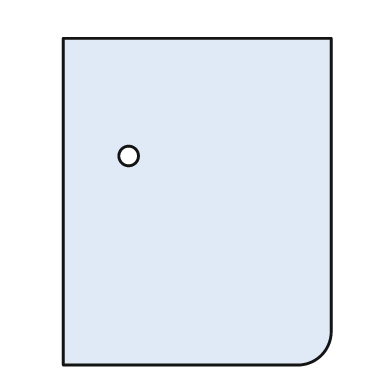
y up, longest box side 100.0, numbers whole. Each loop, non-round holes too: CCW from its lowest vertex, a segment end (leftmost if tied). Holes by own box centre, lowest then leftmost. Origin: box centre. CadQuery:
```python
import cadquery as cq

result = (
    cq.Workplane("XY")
    .moveTo(-41.0, -50.0)
    .lineTo(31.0, -50.0)
    .threePointArc((38.0, -47.0), (41.0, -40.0))
    .lineTo(41.0, 50.0)
    .lineTo(-41.0, 50.0)
    .close()
    .moveTo(-21.0, 14.0)
    .circle(3.0)
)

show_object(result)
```